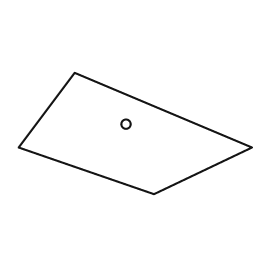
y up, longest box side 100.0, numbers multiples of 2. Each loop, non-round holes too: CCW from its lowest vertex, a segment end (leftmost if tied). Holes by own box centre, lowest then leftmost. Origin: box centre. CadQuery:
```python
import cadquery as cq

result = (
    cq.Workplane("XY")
    .moveTo(8.0, -26.0)
    .lineTo(50.0, -6.0)
    .lineTo(-26.0, 26.0)
    .lineTo(-50.0, -6.0)
    .close()
    .moveTo(-4.0, 4.0)
    .circle(2.0)
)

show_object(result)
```